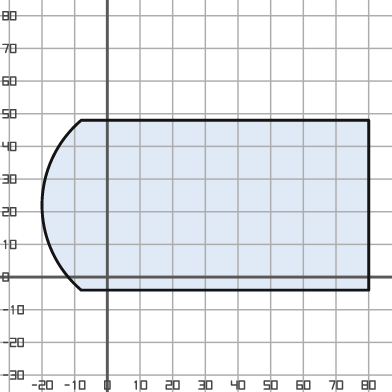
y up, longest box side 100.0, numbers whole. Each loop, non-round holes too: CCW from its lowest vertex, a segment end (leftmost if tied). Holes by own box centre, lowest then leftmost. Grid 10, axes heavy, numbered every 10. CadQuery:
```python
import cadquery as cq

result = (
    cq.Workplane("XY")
    .moveTo(-8.0, -4.0)
    .lineTo(80.0, -4.0)
    .lineTo(80.0, 48.0)
    .lineTo(-8.0, 48.0)
    .threePointArc((-20.0, 22.0), (-8.0, -4.0))
    .close()
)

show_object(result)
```